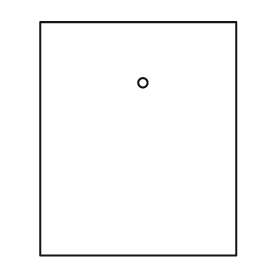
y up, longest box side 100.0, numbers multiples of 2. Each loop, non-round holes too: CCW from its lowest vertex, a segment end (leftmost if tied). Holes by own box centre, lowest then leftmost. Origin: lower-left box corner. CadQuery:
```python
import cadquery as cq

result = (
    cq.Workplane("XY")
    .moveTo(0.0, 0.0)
    .lineTo(84.0, 0.0)
    .lineTo(84.0, 100.0)
    .lineTo(0.0, 100.0)
    .close()
    .moveTo(44.0, 74.0)
    .circle(2.0)
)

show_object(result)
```